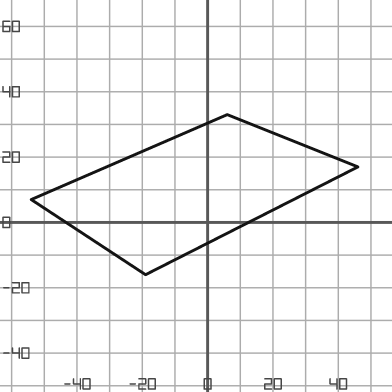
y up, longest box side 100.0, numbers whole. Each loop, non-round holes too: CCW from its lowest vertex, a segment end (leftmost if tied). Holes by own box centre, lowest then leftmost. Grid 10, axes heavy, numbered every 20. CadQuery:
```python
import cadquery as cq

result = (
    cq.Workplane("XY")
    .moveTo(-19.0, -16.0)
    .lineTo(46.0, 17.0)
    .lineTo(6.0, 33.0)
    .lineTo(-54.0, 7.0)
    .close()
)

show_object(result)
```